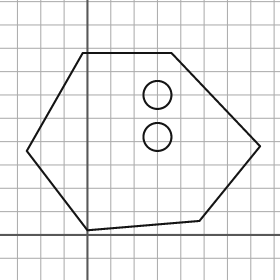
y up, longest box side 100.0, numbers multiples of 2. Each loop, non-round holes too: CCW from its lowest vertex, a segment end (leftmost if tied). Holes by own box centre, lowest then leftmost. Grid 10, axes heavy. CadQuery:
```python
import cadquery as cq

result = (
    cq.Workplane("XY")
    .moveTo(0.0, 2.0)
    .lineTo(48.0, 6.0)
    .lineTo(74.0, 38.0)
    .lineTo(36.0, 78.0)
    .lineTo(-2.0, 78.0)
    .lineTo(-26.0, 36.0)
    .close()
    .moveTo(30.0, 42.0)
    .circle(6.0)
    .moveTo(30.0, 60.0)
    .circle(6.0)
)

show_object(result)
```